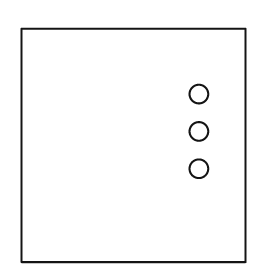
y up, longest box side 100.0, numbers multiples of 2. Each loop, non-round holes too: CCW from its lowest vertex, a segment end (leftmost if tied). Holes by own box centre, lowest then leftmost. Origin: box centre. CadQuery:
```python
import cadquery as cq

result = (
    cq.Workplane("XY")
    .moveTo(-48.0, -50.0)
    .lineTo(48.0, -50.0)
    .lineTo(48.0, 50.0)
    .lineTo(-48.0, 50.0)
    .close()
    .moveTo(28.0, -10.0)
    .circle(4.0)
    .moveTo(28.0, 6.0)
    .circle(4.0)
    .moveTo(28.0, 22.0)
    .circle(4.0)
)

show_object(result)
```